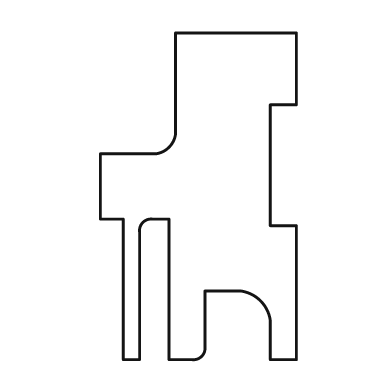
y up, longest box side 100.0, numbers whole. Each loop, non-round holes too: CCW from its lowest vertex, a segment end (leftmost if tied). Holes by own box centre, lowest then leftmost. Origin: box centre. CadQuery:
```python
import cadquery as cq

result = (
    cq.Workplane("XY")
    .moveTo(-23.0, -50.0)
    .lineTo(-18.0, -50.0)
    .lineTo(-18.0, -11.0)
    .threePointArc((-17.0, -8.0), (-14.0, -7.0))
    .lineTo(-9.0, -7.0)
    .lineTo(-9.0, -50.0)
    .lineTo(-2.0, -50.0)
    .threePointArc((1.0, -49.0), (2.0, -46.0))
    .lineTo(2.0, -29.0)
    .lineTo(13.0, -29.0)
    .threePointArc((19.0, -32.0), (22.0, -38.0))
    .lineTo(22.0, -50.0)
    .lineTo(30.0, -50.0)
    .lineTo(30.0, -9.0)
    .lineTo(22.0, -9.0)
    .lineTo(22.0, 28.0)
    .lineTo(30.0, 28.0)
    .lineTo(30.0, 50.0)
    .lineTo(-7.0, 50.0)
    .lineTo(-7.0, 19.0)
    .threePointArc((-9.0, 15.0), (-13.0, 13.0))
    .lineTo(-30.0, 13.0)
    .lineTo(-30.0, -7.0)
    .lineTo(-23.0, -7.0)
    .close()
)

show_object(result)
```